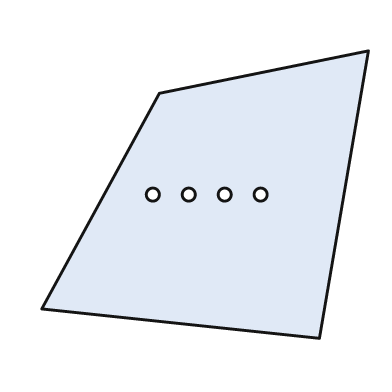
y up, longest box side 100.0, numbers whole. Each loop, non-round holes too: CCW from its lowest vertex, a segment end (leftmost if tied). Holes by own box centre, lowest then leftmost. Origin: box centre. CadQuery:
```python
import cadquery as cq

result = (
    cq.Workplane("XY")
    .moveTo(35.0, -44.0)
    .lineTo(50.0, 44.0)
    .lineTo(-14.0, 31.0)
    .lineTo(-50.0, -35.0)
    .close()
    .moveTo(-16.0, 0.0)
    .circle(2.0)
    .moveTo(-5.0, 0.0)
    .circle(2.0)
    .moveTo(6.0, 0.0)
    .circle(2.0)
    .moveTo(17.0, 0.0)
    .circle(2.0)
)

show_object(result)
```